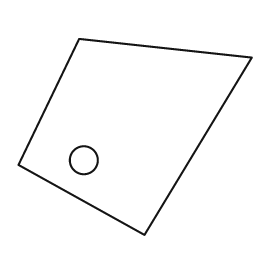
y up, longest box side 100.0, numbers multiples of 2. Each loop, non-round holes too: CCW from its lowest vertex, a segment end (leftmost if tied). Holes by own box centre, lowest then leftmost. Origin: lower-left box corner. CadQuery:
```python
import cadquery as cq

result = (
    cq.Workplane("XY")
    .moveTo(54.0, 0.0)
    .lineTo(100.0, 76.0)
    .lineTo(26.0, 84.0)
    .lineTo(0.0, 30.0)
    .close()
    .moveTo(28.0, 32.0)
    .circle(6.0)
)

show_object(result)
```